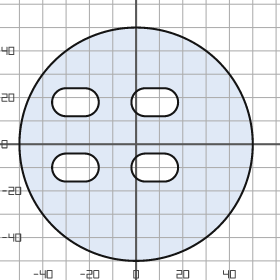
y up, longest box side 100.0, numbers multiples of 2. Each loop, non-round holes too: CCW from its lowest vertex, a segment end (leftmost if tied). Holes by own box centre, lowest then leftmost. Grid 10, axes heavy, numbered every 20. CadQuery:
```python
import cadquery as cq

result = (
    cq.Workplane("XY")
    .moveTo(0.0, 0.0)
    .circle(50.0)
    .moveTo(-30.0, -16.0)
    .lineTo(-22.0, -16.0)
    .threePointArc((-16.0, -10.0), (-22.0, -4.0))
    .lineTo(-30.0, -4.0)
    .threePointArc((-36.0, -10.0), (-30.0, -16.0))
    .close()
    .moveTo(4.0, -16.0)
    .lineTo(12.0, -16.0)
    .threePointArc((18.0, -10.0), (12.0, -4.0))
    .lineTo(4.0, -4.0)
    .threePointArc((-2.0, -10.0), (4.0, -16.0))
    .close()
    .moveTo(-30.0, 12.0)
    .lineTo(-22.0, 12.0)
    .threePointArc((-16.0, 18.0), (-22.0, 24.0))
    .lineTo(-30.0, 24.0)
    .threePointArc((-36.0, 18.0), (-30.0, 12.0))
    .close()
    .moveTo(4.0, 12.0)
    .lineTo(12.0, 12.0)
    .threePointArc((18.0, 18.0), (12.0, 24.0))
    .lineTo(4.0, 24.0)
    .threePointArc((-2.0, 18.0), (4.0, 12.0))
    .close()
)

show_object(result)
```